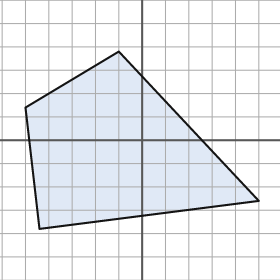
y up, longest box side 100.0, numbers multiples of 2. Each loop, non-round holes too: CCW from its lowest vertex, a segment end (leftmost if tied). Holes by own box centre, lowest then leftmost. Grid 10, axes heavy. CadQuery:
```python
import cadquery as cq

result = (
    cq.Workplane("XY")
    .moveTo(-44.0, -38.0)
    .lineTo(50.0, -26.0)
    .lineTo(-10.0, 38.0)
    .lineTo(-50.0, 14.0)
    .close()
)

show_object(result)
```